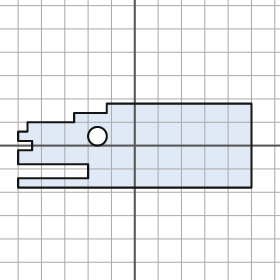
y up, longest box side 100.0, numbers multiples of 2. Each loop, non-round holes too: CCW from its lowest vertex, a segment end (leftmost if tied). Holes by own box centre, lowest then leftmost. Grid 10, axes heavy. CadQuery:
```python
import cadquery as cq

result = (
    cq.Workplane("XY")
    .moveTo(-50.0, -18.0)
    .lineTo(50.0, -18.0)
    .lineTo(50.0, 18.0)
    .lineTo(-12.0, 18.0)
    .lineTo(-12.0, 14.0)
    .lineTo(-26.0, 14.0)
    .lineTo(-26.0, 10.0)
    .lineTo(-46.0, 10.0)
    .lineTo(-46.0, 6.0)
    .lineTo(-50.0, 6.0)
    .lineTo(-50.0, 2.0)
    .lineTo(-44.0, 2.0)
    .lineTo(-44.0, -2.0)
    .lineTo(-50.0, -2.0)
    .lineTo(-50.0, -8.0)
    .lineTo(-20.0, -8.0)
    .lineTo(-20.0, -14.0)
    .lineTo(-50.0, -14.0)
    .close()
    .moveTo(-16.0, 4.0)
    .circle(4.0)
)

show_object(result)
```